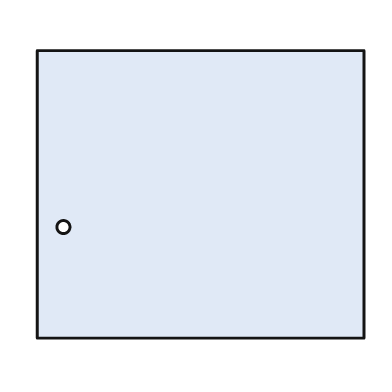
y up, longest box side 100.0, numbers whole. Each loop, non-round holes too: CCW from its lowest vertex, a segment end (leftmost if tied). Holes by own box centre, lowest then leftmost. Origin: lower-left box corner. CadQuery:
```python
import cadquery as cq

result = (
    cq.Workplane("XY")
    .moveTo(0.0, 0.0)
    .lineTo(100.0, 0.0)
    .lineTo(100.0, 88.0)
    .lineTo(0.0, 88.0)
    .close()
    .moveTo(8.0, 34.0)
    .circle(2.0)
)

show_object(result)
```